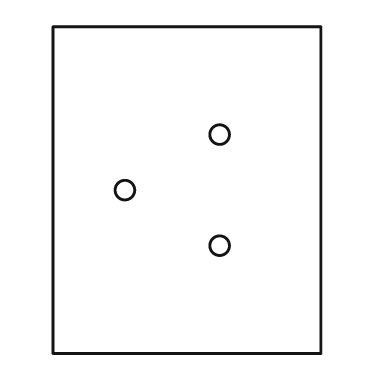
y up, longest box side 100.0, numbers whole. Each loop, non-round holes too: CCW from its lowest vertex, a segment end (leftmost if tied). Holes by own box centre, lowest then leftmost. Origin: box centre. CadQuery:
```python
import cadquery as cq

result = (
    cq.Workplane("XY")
    .moveTo(-41.0, -50.0)
    .lineTo(41.0, -50.0)
    .lineTo(41.0, 50.0)
    .lineTo(-41.0, 50.0)
    .close()
    .moveTo(10.0, -17.0)
    .circle(3.0)
    .moveTo(-19.0, 0.0)
    .circle(3.0)
    .moveTo(10.0, 17.0)
    .circle(3.0)
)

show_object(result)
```